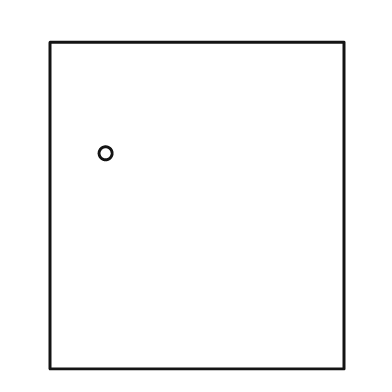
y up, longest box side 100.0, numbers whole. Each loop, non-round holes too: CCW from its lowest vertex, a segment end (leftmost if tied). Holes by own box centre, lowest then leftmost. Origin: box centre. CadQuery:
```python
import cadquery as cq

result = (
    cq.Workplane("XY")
    .moveTo(-45.0, -50.0)
    .lineTo(45.0, -50.0)
    .lineTo(45.0, 50.0)
    .lineTo(-45.0, 50.0)
    .close()
    .moveTo(-28.0, 16.0)
    .circle(2.0)
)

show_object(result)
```